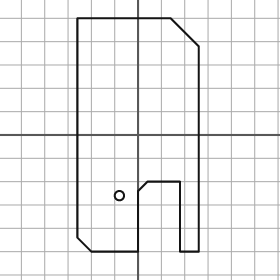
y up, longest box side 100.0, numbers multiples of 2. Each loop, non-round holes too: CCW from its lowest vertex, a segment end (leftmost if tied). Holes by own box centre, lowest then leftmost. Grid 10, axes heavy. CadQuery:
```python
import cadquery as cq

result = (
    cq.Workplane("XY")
    .moveTo(-20.0, -50.0)
    .lineTo(0.0, -50.0)
    .lineTo(0.0, -24.0)
    .lineTo(4.0, -20.0)
    .lineTo(18.0, -20.0)
    .lineTo(18.0, -50.0)
    .lineTo(26.0, -50.0)
    .lineTo(26.0, 38.0)
    .lineTo(14.0, 50.0)
    .lineTo(-26.0, 50.0)
    .lineTo(-26.0, -44.0)
    .close()
    .moveTo(-8.0, -26.0)
    .circle(2.0)
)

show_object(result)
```